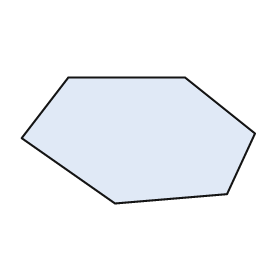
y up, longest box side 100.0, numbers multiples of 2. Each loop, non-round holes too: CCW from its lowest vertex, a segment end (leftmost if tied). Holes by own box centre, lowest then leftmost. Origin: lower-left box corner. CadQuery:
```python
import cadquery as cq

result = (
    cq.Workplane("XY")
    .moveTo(40.0, 0.0)
    .lineTo(88.0, 4.0)
    .lineTo(100.0, 30.0)
    .lineTo(70.0, 54.0)
    .lineTo(20.0, 54.0)
    .lineTo(0.0, 28.0)
    .close()
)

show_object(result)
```